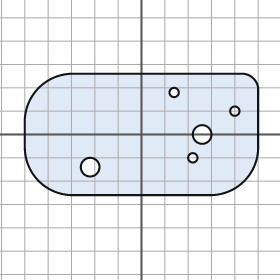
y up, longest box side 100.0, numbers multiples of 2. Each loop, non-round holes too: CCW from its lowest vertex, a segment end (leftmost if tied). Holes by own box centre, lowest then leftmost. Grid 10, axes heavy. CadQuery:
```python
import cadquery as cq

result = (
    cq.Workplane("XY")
    .moveTo(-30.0, -26.0)
    .lineTo(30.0, -26.0)
    .threePointArc((44.0, -20.0), (50.0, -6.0))
    .lineTo(50.0, 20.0)
    .threePointArc((48.0, 24.0), (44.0, 26.0))
    .lineTo(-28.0, 26.0)
    .threePointArc((-44.0, 20.0), (-50.0, 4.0))
    .lineTo(-50.0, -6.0)
    .threePointArc((-44.0, -20.0), (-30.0, -26.0))
    .close()
    .moveTo(-22.0, -14.0)
    .circle(4.0)
    .moveTo(22.0, -10.0)
    .circle(2.0)
    .moveTo(26.0, 0.0)
    .circle(4.0)
    .moveTo(40.0, 10.0)
    .circle(2.0)
    .moveTo(14.0, 18.0)
    .circle(2.0)
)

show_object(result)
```